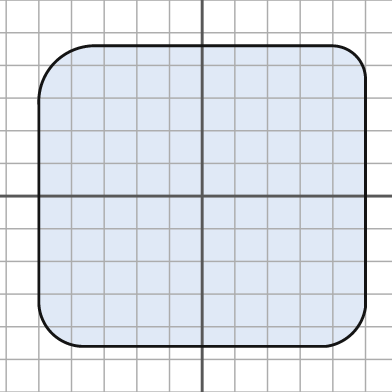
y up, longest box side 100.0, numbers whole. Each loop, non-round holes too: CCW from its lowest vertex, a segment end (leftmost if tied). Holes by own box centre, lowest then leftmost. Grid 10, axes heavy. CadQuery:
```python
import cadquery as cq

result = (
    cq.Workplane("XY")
    .moveTo(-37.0, -46.0)
    .lineTo(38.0, -46.0)
    .threePointArc((46.0, -42.0), (50.0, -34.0))
    .lineTo(50.0, 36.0)
    .threePointArc((47.0, 43.0), (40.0, 46.0))
    .lineTo(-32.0, 46.0)
    .threePointArc((-45.0, 41.0), (-50.0, 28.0))
    .lineTo(-50.0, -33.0)
    .threePointArc((-46.0, -42.0), (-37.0, -46.0))
    .close()
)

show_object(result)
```